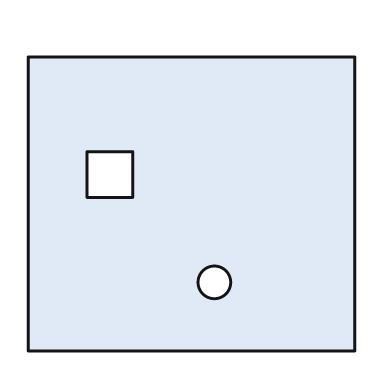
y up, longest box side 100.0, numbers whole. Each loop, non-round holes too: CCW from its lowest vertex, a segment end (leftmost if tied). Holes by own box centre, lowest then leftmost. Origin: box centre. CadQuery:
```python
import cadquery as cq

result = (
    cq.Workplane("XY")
    .moveTo(-50.0, -45.0)
    .lineTo(50.0, -45.0)
    .lineTo(50.0, 45.0)
    .lineTo(-50.0, 45.0)
    .close()
    .moveTo(7.0, -24.0)
    .circle(5.0)
    .moveTo(-32.0, 2.0)
    .lineTo(-18.0, 2.0)
    .lineTo(-18.0, 16.0)
    .lineTo(-32.0, 16.0)
    .close()
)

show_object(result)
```